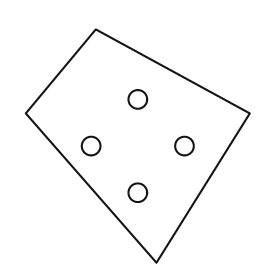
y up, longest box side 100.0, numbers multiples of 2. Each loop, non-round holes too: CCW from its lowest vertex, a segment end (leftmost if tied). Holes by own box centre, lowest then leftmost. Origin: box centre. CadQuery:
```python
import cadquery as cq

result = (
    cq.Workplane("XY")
    .moveTo(8.0, -50.0)
    .lineTo(48.0, 14.0)
    .lineTo(-18.0, 50.0)
    .lineTo(-48.0, 14.0)
    .close()
    .moveTo(0.0, -20.0)
    .circle(4.0)
    .moveTo(-20.0, 0.0)
    .circle(4.0)
    .moveTo(20.0, 0.0)
    .circle(4.0)
    .moveTo(0.0, 20.0)
    .circle(4.0)
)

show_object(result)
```